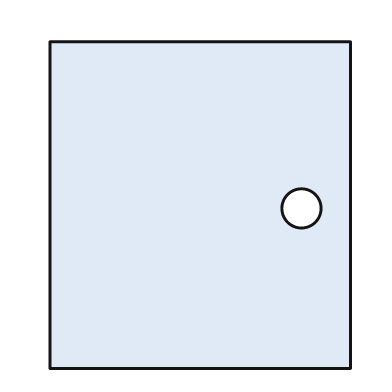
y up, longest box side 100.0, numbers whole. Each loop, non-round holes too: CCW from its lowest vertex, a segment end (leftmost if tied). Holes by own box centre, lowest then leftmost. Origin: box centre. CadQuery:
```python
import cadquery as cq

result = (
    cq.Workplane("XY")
    .moveTo(-46.0, -50.0)
    .lineTo(46.0, -50.0)
    .lineTo(46.0, 50.0)
    .lineTo(-46.0, 50.0)
    .close()
    .moveTo(31.0, -1.0)
    .circle(6.0)
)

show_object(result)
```